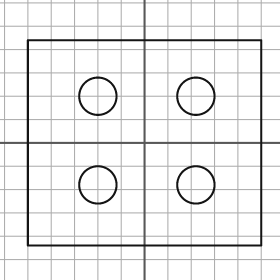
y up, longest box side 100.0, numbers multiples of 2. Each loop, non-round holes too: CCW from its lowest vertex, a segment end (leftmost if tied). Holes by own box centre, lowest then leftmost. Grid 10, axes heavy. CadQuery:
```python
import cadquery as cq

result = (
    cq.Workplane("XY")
    .moveTo(-50.0, -44.0)
    .lineTo(50.0, -44.0)
    .lineTo(50.0, 44.0)
    .lineTo(-50.0, 44.0)
    .close()
    .moveTo(-20.0, -18.0)
    .circle(8.0)
    .moveTo(22.0, -18.0)
    .circle(8.0)
    .moveTo(-20.0, 20.0)
    .circle(8.0)
    .moveTo(22.0, 20.0)
    .circle(8.0)
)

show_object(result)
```